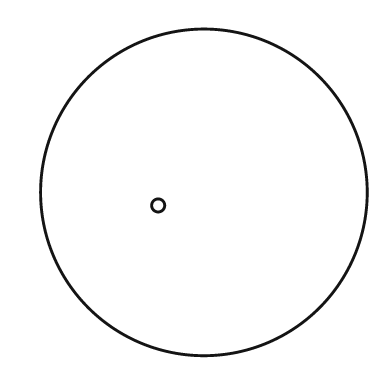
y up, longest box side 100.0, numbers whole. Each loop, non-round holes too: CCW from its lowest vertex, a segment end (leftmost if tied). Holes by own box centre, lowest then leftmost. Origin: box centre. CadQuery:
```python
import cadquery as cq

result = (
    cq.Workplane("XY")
    .moveTo(0.0, 0.0)
    .circle(50.0)
    .moveTo(-14.0, -4.0)
    .circle(2.0)
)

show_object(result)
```